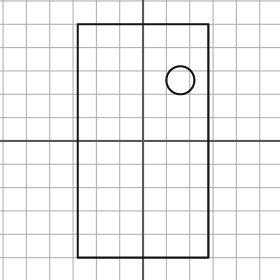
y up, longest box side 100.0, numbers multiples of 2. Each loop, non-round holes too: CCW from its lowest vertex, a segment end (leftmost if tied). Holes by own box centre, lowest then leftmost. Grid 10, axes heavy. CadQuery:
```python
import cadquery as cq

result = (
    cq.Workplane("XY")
    .moveTo(-28.0, -50.0)
    .lineTo(28.0, -50.0)
    .lineTo(28.0, 50.0)
    .lineTo(-28.0, 50.0)
    .close()
    .moveTo(16.0, 26.0)
    .circle(6.0)
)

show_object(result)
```